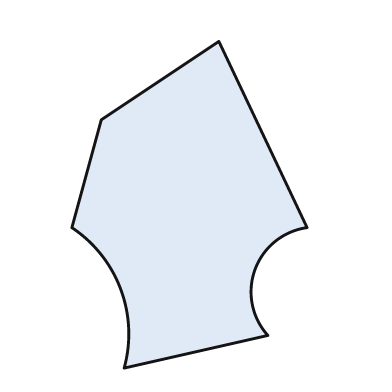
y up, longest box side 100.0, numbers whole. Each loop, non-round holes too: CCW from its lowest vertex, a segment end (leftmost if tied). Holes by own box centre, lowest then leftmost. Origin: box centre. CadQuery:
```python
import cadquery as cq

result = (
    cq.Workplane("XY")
    .moveTo(-20.0, -50.0)
    .lineTo(24.0, -40.0)
    .threePointArc((20.0, -20.0), (36.0, -7.0))
    .lineTo(9.0, 50.0)
    .lineTo(-27.0, 26.0)
    .lineTo(-36.0, -7.0)
    .threePointArc((-21.0, -26.0), (-20.0, -50.0))
    .close()
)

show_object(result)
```